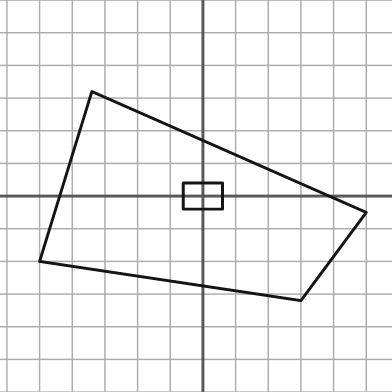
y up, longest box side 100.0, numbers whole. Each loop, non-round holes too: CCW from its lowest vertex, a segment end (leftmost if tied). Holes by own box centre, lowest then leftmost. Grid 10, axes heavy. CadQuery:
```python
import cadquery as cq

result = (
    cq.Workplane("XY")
    .moveTo(30.0, -32.0)
    .lineTo(50.0, -5.0)
    .lineTo(-34.0, 32.0)
    .lineTo(-50.0, -20.0)
    .close()
    .moveTo(-6.0, -4.0)
    .lineTo(6.0, -4.0)
    .lineTo(6.0, 4.0)
    .lineTo(-6.0, 4.0)
    .close()
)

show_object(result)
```